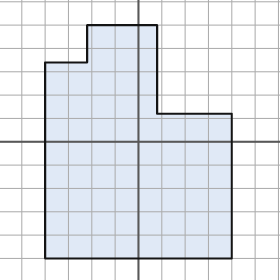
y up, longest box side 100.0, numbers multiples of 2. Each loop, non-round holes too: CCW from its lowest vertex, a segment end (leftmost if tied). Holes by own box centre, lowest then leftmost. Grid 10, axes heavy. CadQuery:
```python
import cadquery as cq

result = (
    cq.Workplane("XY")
    .moveTo(-40.0, -50.0)
    .lineTo(40.0, -50.0)
    .lineTo(40.0, 12.0)
    .lineTo(8.0, 12.0)
    .lineTo(8.0, 50.0)
    .lineTo(-22.0, 50.0)
    .lineTo(-22.0, 34.0)
    .lineTo(-40.0, 34.0)
    .close()
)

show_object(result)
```